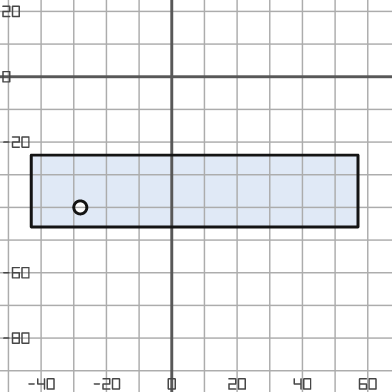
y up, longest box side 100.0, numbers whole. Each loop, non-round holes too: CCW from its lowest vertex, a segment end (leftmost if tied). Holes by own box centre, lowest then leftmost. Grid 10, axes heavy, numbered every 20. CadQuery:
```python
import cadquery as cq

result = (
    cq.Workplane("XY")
    .moveTo(-43.0, -46.0)
    .lineTo(57.0, -46.0)
    .lineTo(57.0, -24.0)
    .lineTo(-43.0, -24.0)
    .close()
    .moveTo(-28.0, -40.0)
    .circle(2.0)
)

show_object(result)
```